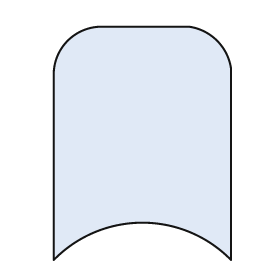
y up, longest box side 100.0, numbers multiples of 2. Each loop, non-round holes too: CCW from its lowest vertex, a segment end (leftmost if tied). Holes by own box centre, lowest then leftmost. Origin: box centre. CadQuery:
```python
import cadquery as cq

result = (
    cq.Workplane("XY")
    .moveTo(-38.0, -50.0)
    .threePointArc((0.0, -34.0), (38.0, -50.0))
    .lineTo(38.0, 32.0)
    .threePointArc((32.0, 44.0), (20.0, 50.0))
    .lineTo(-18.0, 50.0)
    .threePointArc((-32.0, 44.0), (-38.0, 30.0))
    .close()
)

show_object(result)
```